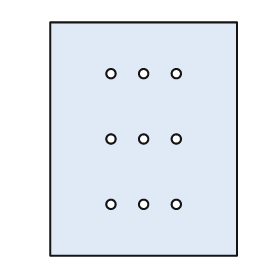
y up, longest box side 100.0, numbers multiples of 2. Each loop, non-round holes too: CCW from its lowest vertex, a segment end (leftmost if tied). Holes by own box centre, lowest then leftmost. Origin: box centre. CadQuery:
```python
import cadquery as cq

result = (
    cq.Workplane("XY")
    .moveTo(-40.0, -50.0)
    .lineTo(40.0, -50.0)
    .lineTo(40.0, 50.0)
    .lineTo(-40.0, 50.0)
    .close()
    .moveTo(-14.0, -28.0)
    .circle(2.0)
    .moveTo(0.0, -28.0)
    .circle(2.0)
    .moveTo(14.0, -28.0)
    .circle(2.0)
    .moveTo(-14.0, 0.0)
    .circle(2.0)
    .moveTo(0.0, 0.0)
    .circle(2.0)
    .moveTo(14.0, 0.0)
    .circle(2.0)
    .moveTo(-14.0, 28.0)
    .circle(2.0)
    .moveTo(0.0, 28.0)
    .circle(2.0)
    .moveTo(14.0, 28.0)
    .circle(2.0)
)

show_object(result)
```